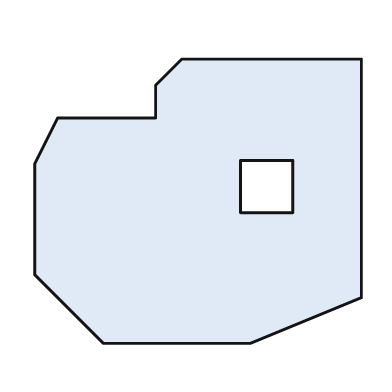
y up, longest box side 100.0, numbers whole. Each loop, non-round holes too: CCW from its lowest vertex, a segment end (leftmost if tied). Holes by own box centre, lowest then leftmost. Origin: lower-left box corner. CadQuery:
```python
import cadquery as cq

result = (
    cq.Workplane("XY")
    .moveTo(21.0, 0.0)
    .lineTo(66.0, 0.0)
    .lineTo(100.0, 14.0)
    .lineTo(100.0, 87.0)
    .lineTo(45.0, 87.0)
    .lineTo(37.0, 79.0)
    .lineTo(37.0, 69.0)
    .lineTo(7.0, 69.0)
    .lineTo(0.0, 55.0)
    .lineTo(0.0, 21.0)
    .close()
    .moveTo(63.0, 40.0)
    .lineTo(79.0, 40.0)
    .lineTo(79.0, 56.0)
    .lineTo(63.0, 56.0)
    .close()
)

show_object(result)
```